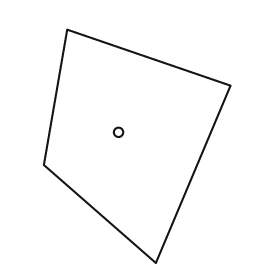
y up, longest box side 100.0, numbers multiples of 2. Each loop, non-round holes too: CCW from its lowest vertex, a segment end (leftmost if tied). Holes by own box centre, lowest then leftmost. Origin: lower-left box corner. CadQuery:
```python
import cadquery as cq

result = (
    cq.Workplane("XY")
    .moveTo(48.0, 0.0)
    .lineTo(80.0, 76.0)
    .lineTo(10.0, 100.0)
    .lineTo(0.0, 42.0)
    .close()
    .moveTo(32.0, 56.0)
    .circle(2.0)
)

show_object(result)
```